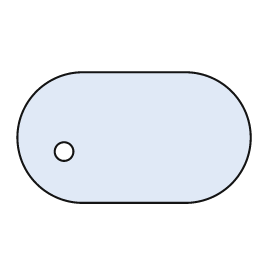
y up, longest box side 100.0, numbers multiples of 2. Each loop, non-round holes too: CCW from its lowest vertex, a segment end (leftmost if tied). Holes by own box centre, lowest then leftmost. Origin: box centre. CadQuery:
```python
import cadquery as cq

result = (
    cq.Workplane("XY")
    .moveTo(-22.0, -28.0)
    .lineTo(22.0, -28.0)
    .threePointArc((50.0, 0.0), (22.0, 28.0))
    .lineTo(-22.0, 28.0)
    .threePointArc((-50.0, 0.0), (-22.0, -28.0))
    .close()
    .moveTo(-30.0, -6.0)
    .circle(4.0)
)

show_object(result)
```